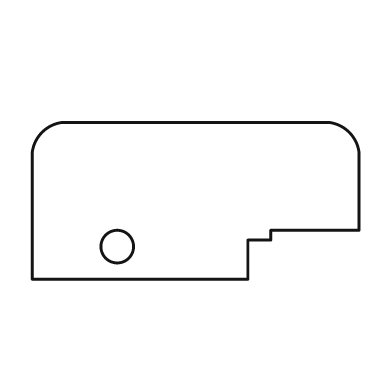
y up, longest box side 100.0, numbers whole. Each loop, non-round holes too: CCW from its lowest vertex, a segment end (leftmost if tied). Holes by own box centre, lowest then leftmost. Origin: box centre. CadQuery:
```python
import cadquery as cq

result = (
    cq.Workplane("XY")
    .moveTo(-50.0, -24.0)
    .lineTo(16.0, -24.0)
    .lineTo(16.0, -12.0)
    .lineTo(23.0, -12.0)
    .lineTo(23.0, -9.0)
    .lineTo(50.0, -9.0)
    .lineTo(50.0, 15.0)
    .threePointArc((47.0, 21.0), (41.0, 24.0))
    .lineTo(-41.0, 24.0)
    .threePointArc((-47.0, 21.0), (-50.0, 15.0))
    .close()
    .moveTo(-24.0, -14.0)
    .circle(5.0)
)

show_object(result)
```